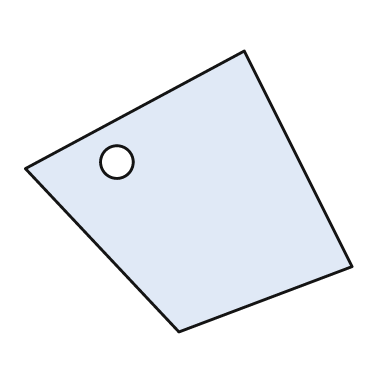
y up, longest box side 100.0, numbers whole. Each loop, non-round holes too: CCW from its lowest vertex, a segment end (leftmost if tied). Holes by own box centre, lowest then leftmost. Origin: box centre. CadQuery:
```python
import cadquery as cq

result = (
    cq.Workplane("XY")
    .moveTo(-3.0, -43.0)
    .lineTo(50.0, -23.0)
    .lineTo(17.0, 43.0)
    .lineTo(-50.0, 7.0)
    .close()
    .moveTo(-22.0, 9.0)
    .circle(5.0)
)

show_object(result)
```